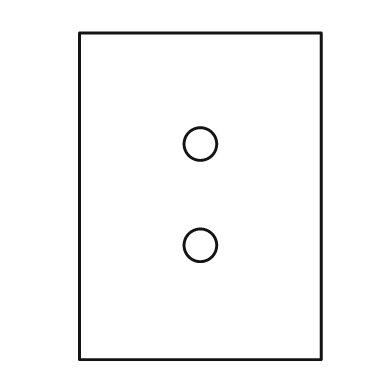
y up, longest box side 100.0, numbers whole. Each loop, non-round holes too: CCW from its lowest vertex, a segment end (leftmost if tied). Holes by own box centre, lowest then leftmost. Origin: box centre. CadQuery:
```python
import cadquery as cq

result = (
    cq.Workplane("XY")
    .moveTo(-37.0, -50.0)
    .lineTo(37.0, -50.0)
    .lineTo(37.0, 50.0)
    .lineTo(-37.0, 50.0)
    .close()
    .moveTo(0.0, -15.0)
    .circle(5.0)
    .moveTo(0.0, 16.0)
    .circle(5.0)
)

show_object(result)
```